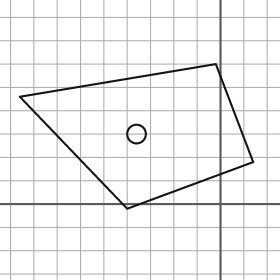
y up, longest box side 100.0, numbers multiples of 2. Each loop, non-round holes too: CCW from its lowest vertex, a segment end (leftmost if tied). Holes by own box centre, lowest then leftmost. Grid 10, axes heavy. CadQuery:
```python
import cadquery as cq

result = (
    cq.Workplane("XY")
    .moveTo(-40.0, -2.0)
    .lineTo(14.0, 18.0)
    .lineTo(-2.0, 60.0)
    .lineTo(-86.0, 46.0)
    .close()
    .moveTo(-36.0, 30.0)
    .circle(4.0)
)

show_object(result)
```